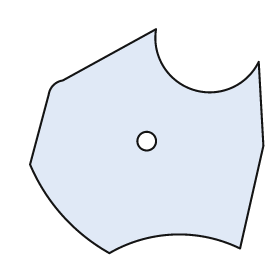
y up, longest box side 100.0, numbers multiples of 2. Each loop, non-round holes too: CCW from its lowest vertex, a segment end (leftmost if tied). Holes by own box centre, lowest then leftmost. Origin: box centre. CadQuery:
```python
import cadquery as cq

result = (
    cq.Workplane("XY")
    .moveTo(-16.0, -48.0)
    .threePointArc((12.0, -40.0), (40.0, -46.0))
    .lineTo(50.0, -2.0)
    .lineTo(48.0, 34.0)
    .threePointArc((20.0, 22.0), (4.0, 48.0))
    .lineTo(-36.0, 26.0)
    .threePointArc((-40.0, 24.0), (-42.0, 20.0))
    .lineTo(-50.0, -10.0)
    .threePointArc((-36.0, -32.0), (-16.0, -48.0))
    .close()
    .moveTo(0.0, 0.0)
    .circle(4.0)
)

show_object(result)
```